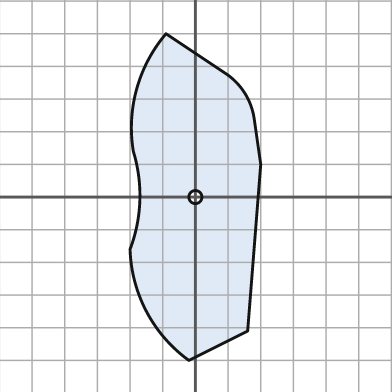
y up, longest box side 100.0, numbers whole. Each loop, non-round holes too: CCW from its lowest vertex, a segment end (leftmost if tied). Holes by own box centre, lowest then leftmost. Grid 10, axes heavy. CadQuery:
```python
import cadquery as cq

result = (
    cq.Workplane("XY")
    .moveTo(-2.0, -50.0)
    .lineTo(16.0, -41.0)
    .lineTo(20.0, 10.0)
    .lineTo(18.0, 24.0)
    .threePointArc((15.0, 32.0), (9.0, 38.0))
    .lineTo(-9.0, 50.0)
    .threePointArc((-18.0, 33.0), (-19.0, 14.0))
    .threePointArc((-17.0, -1.0), (-20.0, -16.0))
    .threePointArc((-15.0, -35.0), (-2.0, -50.0))
    .close()
    .moveTo(0.0, 0.0)
    .circle(2.0)
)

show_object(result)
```